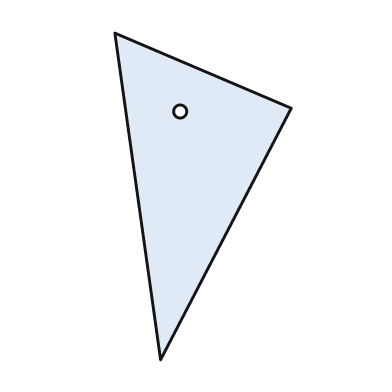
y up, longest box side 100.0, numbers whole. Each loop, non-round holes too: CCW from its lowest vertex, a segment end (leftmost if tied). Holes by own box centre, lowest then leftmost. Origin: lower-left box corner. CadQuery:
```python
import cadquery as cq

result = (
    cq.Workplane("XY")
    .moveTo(14.0, 0.0)
    .lineTo(54.0, 77.0)
    .lineTo(0.0, 100.0)
    .close()
    .moveTo(20.0, 76.0)
    .circle(2.0)
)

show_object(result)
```